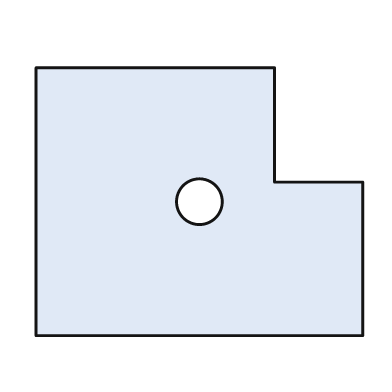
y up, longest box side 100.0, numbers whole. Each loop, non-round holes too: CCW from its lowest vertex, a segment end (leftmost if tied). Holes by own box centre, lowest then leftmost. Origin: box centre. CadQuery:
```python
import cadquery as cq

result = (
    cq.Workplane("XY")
    .moveTo(-50.0, -41.0)
    .lineTo(50.0, -41.0)
    .lineTo(50.0, 6.0)
    .lineTo(23.0, 6.0)
    .lineTo(23.0, 41.0)
    .lineTo(-50.0, 41.0)
    .close()
    .moveTo(0.0, 0.0)
    .circle(7.0)
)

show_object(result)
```